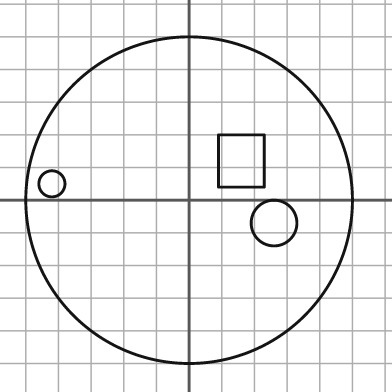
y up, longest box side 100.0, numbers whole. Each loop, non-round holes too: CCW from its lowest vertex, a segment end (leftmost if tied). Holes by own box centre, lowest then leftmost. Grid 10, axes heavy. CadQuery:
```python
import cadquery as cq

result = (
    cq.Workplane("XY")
    .moveTo(0.0, 0.0)
    .circle(50.0)
    .moveTo(26.0, -7.0)
    .circle(7.0)
    .moveTo(-42.0, 5.0)
    .circle(4.0)
    .moveTo(9.0, 4.0)
    .lineTo(23.0, 4.0)
    .lineTo(23.0, 20.0)
    .lineTo(9.0, 20.0)
    .close()
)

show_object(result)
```